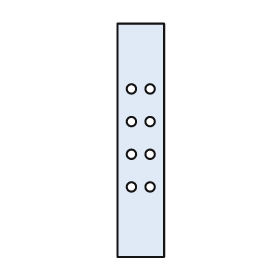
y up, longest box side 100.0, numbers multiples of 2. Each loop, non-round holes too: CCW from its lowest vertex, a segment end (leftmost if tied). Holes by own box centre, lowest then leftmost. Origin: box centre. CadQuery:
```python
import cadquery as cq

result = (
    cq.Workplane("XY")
    .moveTo(-10.0, -50.0)
    .lineTo(10.0, -50.0)
    .lineTo(10.0, 50.0)
    .lineTo(-10.0, 50.0)
    .close()
    .moveTo(-4.0, -20.0)
    .circle(2.0)
    .moveTo(4.0, -20.0)
    .circle(2.0)
    .moveTo(-4.0, -6.0)
    .circle(2.0)
    .moveTo(4.0, -6.0)
    .circle(2.0)
    .moveTo(-4.0, 8.0)
    .circle(2.0)
    .moveTo(4.0, 8.0)
    .circle(2.0)
    .moveTo(-4.0, 22.0)
    .circle(2.0)
    .moveTo(4.0, 22.0)
    .circle(2.0)
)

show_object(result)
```